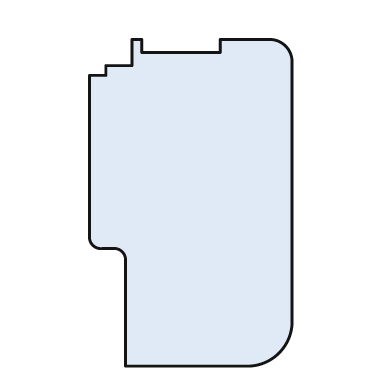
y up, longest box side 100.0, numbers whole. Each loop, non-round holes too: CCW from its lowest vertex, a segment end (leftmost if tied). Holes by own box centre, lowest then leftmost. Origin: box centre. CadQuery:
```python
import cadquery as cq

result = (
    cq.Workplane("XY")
    .moveTo(-20.0, -50.0)
    .lineTo(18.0, -50.0)
    .threePointArc((27.0, -46.0), (31.0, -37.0))
    .lineTo(31.0, 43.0)
    .threePointArc((29.0, 48.0), (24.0, 50.0))
    .lineTo(9.0, 50.0)
    .lineTo(9.0, 46.0)
    .lineTo(-15.0, 46.0)
    .lineTo(-15.0, 50.0)
    .lineTo(-18.0, 50.0)
    .lineTo(-18.0, 42.0)
    .lineTo(-26.0, 42.0)
    .lineTo(-26.0, 39.0)
    .lineTo(-31.0, 39.0)
    .lineTo(-31.0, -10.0)
    .threePointArc((-30.0, -13.0), (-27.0, -14.0))
    .lineTo(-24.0, -14.0)
    .threePointArc((-21.0, -15.0), (-20.0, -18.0))
    .close()
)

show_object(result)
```